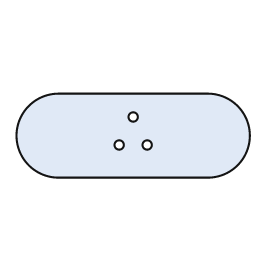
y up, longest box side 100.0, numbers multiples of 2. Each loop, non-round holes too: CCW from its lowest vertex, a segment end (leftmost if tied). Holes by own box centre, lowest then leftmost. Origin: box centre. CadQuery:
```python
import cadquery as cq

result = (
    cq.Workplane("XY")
    .moveTo(-32.0, -18.0)
    .lineTo(32.0, -18.0)
    .threePointArc((50.0, 0.0), (32.0, 18.0))
    .lineTo(-32.0, 18.0)
    .threePointArc((-50.0, 0.0), (-32.0, -18.0))
    .close()
    .moveTo(-6.0, -4.0)
    .circle(2.0)
    .moveTo(6.0, -4.0)
    .circle(2.0)
    .moveTo(0.0, 8.0)
    .circle(2.0)
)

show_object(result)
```